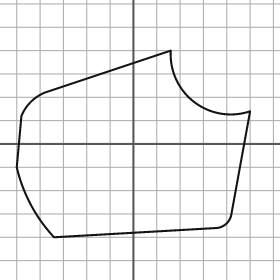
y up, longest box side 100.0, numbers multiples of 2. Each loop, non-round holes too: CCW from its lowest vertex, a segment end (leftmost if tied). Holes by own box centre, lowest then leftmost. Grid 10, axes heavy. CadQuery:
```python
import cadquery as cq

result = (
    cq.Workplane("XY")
    .moveTo(-34.0, -40.0)
    .lineTo(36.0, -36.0)
    .threePointArc((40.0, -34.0), (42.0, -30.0))
    .lineTo(50.0, 14.0)
    .threePointArc((26.0, 18.0), (16.0, 40.0))
    .lineTo(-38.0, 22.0)
    .threePointArc((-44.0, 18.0), (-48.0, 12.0))
    .lineTo(-50.0, -10.0)
    .threePointArc((-44.0, -26.0), (-34.0, -40.0))
    .close()
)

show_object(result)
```